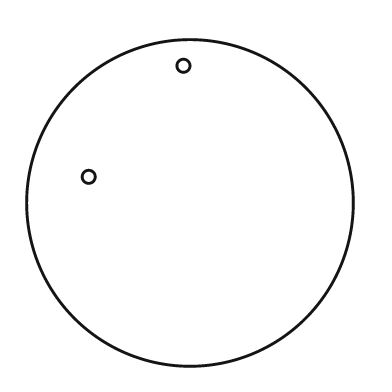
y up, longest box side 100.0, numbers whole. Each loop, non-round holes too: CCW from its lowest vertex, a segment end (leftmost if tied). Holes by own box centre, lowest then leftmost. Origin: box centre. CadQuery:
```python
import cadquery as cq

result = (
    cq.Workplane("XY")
    .moveTo(0.0, 0.0)
    .circle(50.0)
    .moveTo(-31.0, 8.0)
    .circle(2.0)
    .moveTo(-2.0, 42.0)
    .circle(2.0)
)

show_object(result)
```